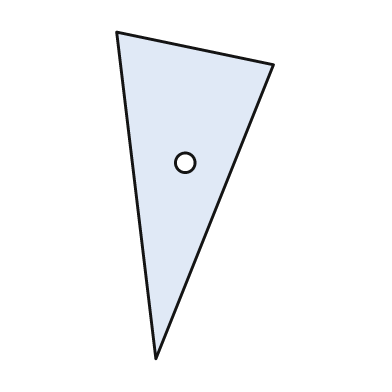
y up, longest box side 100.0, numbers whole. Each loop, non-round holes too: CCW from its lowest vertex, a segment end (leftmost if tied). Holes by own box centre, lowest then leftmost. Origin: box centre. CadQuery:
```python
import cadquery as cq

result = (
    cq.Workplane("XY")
    .moveTo(-12.0, -50.0)
    .lineTo(24.0, 40.0)
    .lineTo(-24.0, 50.0)
    .close()
    .moveTo(-3.0, 10.0)
    .circle(3.0)
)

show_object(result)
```